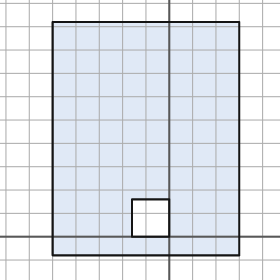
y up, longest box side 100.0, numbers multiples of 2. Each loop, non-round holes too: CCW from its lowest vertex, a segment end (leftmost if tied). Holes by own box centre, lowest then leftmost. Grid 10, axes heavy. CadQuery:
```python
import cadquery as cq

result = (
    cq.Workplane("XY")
    .moveTo(-50.0, -8.0)
    .lineTo(30.0, -8.0)
    .lineTo(30.0, 92.0)
    .lineTo(-50.0, 92.0)
    .close()
    .moveTo(-16.0, 0.0)
    .lineTo(0.0, 0.0)
    .lineTo(0.0, 16.0)
    .lineTo(-16.0, 16.0)
    .close()
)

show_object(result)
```